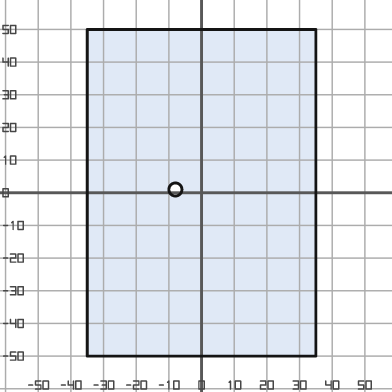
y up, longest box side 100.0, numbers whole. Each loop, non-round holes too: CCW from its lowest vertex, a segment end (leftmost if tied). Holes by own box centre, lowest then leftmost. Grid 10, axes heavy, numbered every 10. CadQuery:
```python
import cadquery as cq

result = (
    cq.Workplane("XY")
    .moveTo(-35.0, -50.0)
    .lineTo(35.0, -50.0)
    .lineTo(35.0, 50.0)
    .lineTo(-35.0, 50.0)
    .close()
    .moveTo(-8.0, 1.0)
    .circle(2.0)
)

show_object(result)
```